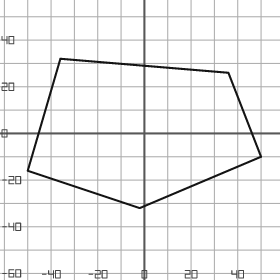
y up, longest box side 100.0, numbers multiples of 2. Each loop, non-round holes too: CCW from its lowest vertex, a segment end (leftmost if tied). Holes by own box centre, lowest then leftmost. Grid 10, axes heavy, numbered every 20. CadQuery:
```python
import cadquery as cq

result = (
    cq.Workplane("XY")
    .moveTo(-2.0, -32.0)
    .lineTo(50.0, -10.0)
    .lineTo(36.0, 26.0)
    .lineTo(-36.0, 32.0)
    .lineTo(-50.0, -16.0)
    .close()
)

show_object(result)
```